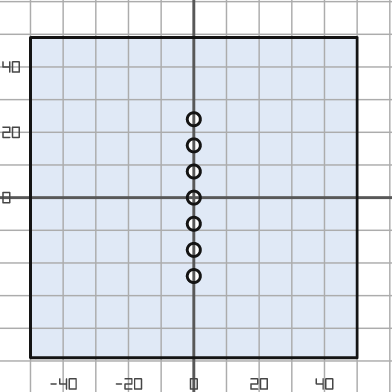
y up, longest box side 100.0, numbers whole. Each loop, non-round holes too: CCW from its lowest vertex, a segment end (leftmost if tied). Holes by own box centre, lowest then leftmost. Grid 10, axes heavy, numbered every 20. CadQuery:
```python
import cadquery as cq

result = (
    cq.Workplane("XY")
    .moveTo(-50.0, -49.0)
    .lineTo(50.0, -49.0)
    .lineTo(50.0, 49.0)
    .lineTo(-50.0, 49.0)
    .close()
    .moveTo(0.0, -24.0)
    .circle(2.0)
    .moveTo(0.0, -16.0)
    .circle(2.0)
    .moveTo(0.0, -8.0)
    .circle(2.0)
    .moveTo(0.0, 0.0)
    .circle(2.0)
    .moveTo(0.0, 8.0)
    .circle(2.0)
    .moveTo(0.0, 16.0)
    .circle(2.0)
    .moveTo(0.0, 24.0)
    .circle(2.0)
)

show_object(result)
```